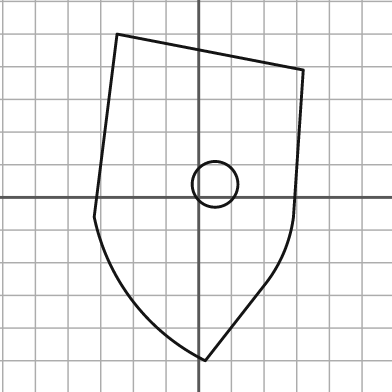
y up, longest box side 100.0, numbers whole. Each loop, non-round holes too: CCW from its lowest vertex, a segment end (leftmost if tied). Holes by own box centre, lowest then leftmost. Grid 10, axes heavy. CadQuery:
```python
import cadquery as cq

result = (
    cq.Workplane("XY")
    .moveTo(2.0, -50.0)
    .lineTo(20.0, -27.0)
    .threePointArc((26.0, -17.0), (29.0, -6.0))
    .lineTo(32.0, 39.0)
    .lineTo(-25.0, 50.0)
    .lineTo(-32.0, -6.0)
    .threePointArc((-20.0, -32.0), (2.0, -50.0))
    .close()
    .moveTo(5.0, 4.0)
    .circle(7.0)
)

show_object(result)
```